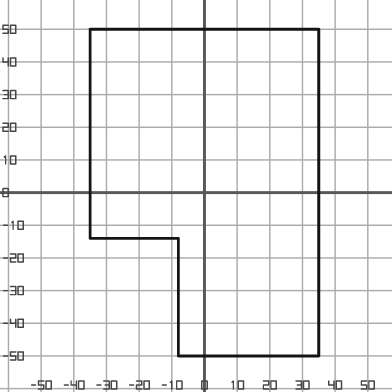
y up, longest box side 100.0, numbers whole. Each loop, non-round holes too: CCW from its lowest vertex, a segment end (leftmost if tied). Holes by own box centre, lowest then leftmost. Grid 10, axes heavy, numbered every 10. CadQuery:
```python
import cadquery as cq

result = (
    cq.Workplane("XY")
    .moveTo(-8.0, -50.0)
    .lineTo(35.0, -50.0)
    .lineTo(35.0, 50.0)
    .lineTo(-35.0, 50.0)
    .lineTo(-35.0, -14.0)
    .lineTo(-8.0, -14.0)
    .close()
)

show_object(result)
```